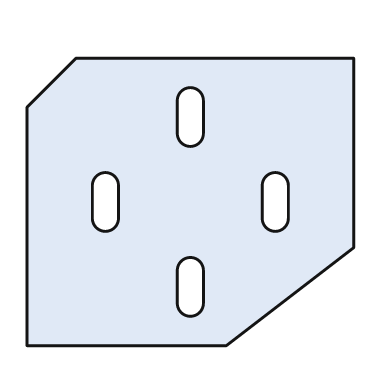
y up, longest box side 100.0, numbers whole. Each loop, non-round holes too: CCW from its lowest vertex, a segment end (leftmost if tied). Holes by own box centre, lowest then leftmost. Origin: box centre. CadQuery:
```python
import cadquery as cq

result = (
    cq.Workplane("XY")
    .moveTo(-50.0, -44.0)
    .lineTo(11.0, -44.0)
    .lineTo(50.0, -14.0)
    .lineTo(50.0, 44.0)
    .lineTo(-35.0, 44.0)
    .lineTo(-50.0, 29.0)
    .close()
    .moveTo(-4.0, -31.0)
    .threePointArc((0.0, -35.0), (4.0, -31.0))
    .lineTo(4.0, -21.0)
    .threePointArc((0.0, -17.0), (-4.0, -21.0))
    .close()
    .moveTo(-30.0, -5.0)
    .threePointArc((-26.0, -9.0), (-22.0, -5.0))
    .lineTo(-22.0, 5.0)
    .threePointArc((-26.0, 9.0), (-30.0, 5.0))
    .close()
    .moveTo(22.0, -5.0)
    .threePointArc((26.0, -9.0), (30.0, -5.0))
    .lineTo(30.0, 5.0)
    .threePointArc((26.0, 9.0), (22.0, 5.0))
    .close()
    .moveTo(-4.0, 21.0)
    .threePointArc((0.0, 17.0), (4.0, 21.0))
    .lineTo(4.0, 31.0)
    .threePointArc((0.0, 35.0), (-4.0, 31.0))
    .close()
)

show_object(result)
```